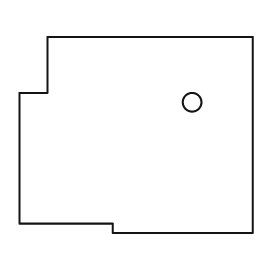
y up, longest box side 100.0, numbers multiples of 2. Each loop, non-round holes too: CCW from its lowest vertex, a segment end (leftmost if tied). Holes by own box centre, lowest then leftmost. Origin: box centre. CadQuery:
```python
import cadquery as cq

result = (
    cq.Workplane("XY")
    .moveTo(-10.0, -42.0)
    .lineTo(50.0, -42.0)
    .lineTo(50.0, 42.0)
    .lineTo(-38.0, 42.0)
    .lineTo(-38.0, 18.0)
    .lineTo(-50.0, 18.0)
    .lineTo(-50.0, -38.0)
    .lineTo(-10.0, -38.0)
    .close()
    .moveTo(24.0, 14.0)
    .circle(4.0)
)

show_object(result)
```